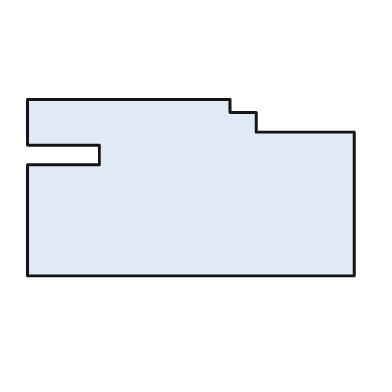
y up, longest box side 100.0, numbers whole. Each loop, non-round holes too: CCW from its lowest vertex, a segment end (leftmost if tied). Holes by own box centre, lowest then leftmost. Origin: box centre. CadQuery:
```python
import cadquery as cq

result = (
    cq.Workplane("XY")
    .moveTo(-50.0, -27.0)
    .lineTo(50.0, -27.0)
    .lineTo(50.0, 17.0)
    .lineTo(20.0, 17.0)
    .lineTo(20.0, 23.0)
    .lineTo(12.0, 23.0)
    .lineTo(12.0, 27.0)
    .lineTo(-50.0, 27.0)
    .lineTo(-50.0, 13.0)
    .lineTo(-28.0, 13.0)
    .lineTo(-28.0, 7.0)
    .lineTo(-50.0, 7.0)
    .close()
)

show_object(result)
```